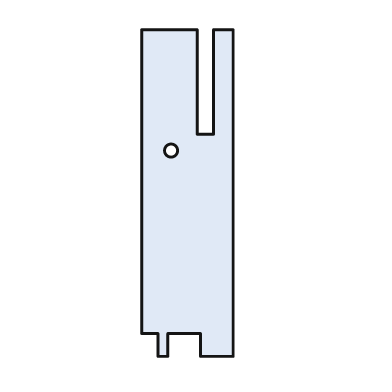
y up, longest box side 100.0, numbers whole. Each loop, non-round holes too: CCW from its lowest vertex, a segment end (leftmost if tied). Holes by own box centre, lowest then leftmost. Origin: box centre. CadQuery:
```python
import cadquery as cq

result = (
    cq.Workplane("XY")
    .moveTo(-9.0, -50.0)
    .lineTo(-6.0, -50.0)
    .lineTo(-6.0, -43.0)
    .lineTo(4.0, -43.0)
    .lineTo(4.0, -50.0)
    .lineTo(14.0, -50.0)
    .lineTo(14.0, 50.0)
    .lineTo(8.0, 50.0)
    .lineTo(8.0, 18.0)
    .lineTo(3.0, 18.0)
    .lineTo(3.0, 50.0)
    .lineTo(-14.0, 50.0)
    .lineTo(-14.0, -43.0)
    .lineTo(-9.0, -43.0)
    .close()
    .moveTo(-5.0, 13.0)
    .circle(2.0)
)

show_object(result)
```